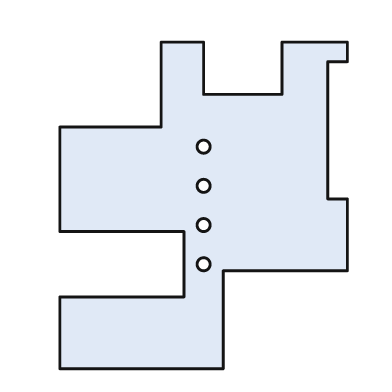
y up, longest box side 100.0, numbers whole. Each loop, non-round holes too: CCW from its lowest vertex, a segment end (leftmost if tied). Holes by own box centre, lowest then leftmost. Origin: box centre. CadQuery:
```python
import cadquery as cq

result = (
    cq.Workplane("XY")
    .moveTo(-44.0, -50.0)
    .lineTo(6.0, -50.0)
    .lineTo(6.0, -20.0)
    .lineTo(44.0, -20.0)
    .lineTo(44.0, 2.0)
    .lineTo(38.0, 2.0)
    .lineTo(38.0, 44.0)
    .lineTo(44.0, 44.0)
    .lineTo(44.0, 50.0)
    .lineTo(24.0, 50.0)
    .lineTo(24.0, 34.0)
    .lineTo(0.0, 34.0)
    .lineTo(0.0, 50.0)
    .lineTo(-13.0, 50.0)
    .lineTo(-13.0, 24.0)
    .lineTo(-44.0, 24.0)
    .lineTo(-44.0, -8.0)
    .lineTo(-6.0, -8.0)
    .lineTo(-6.0, -28.0)
    .lineTo(-44.0, -28.0)
    .close()
    .moveTo(0.0, -18.0)
    .circle(2.0)
    .moveTo(0.0, -6.0)
    .circle(2.0)
    .moveTo(0.0, 6.0)
    .circle(2.0)
    .moveTo(0.0, 18.0)
    .circle(2.0)
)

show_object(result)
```